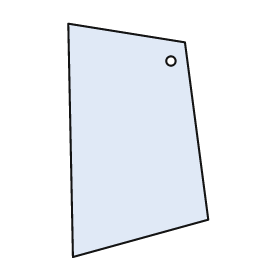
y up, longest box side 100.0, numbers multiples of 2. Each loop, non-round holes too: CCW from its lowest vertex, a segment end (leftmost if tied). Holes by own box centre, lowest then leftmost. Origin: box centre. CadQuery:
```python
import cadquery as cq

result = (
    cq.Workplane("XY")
    .moveTo(-28.0, -50.0)
    .lineTo(30.0, -34.0)
    .lineTo(20.0, 42.0)
    .lineTo(-30.0, 50.0)
    .close()
    .moveTo(14.0, 34.0)
    .circle(2.0)
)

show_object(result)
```